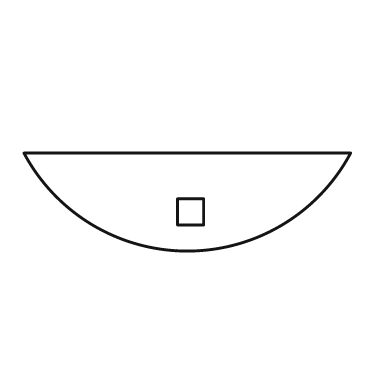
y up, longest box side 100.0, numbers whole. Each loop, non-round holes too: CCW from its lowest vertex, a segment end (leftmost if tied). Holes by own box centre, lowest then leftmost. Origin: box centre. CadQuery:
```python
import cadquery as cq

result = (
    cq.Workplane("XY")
    .moveTo(-50.0, 15.0)
    .threePointArc((0.0, -15.0), (50.0, 15.0))
    .close()
    .moveTo(-3.0, -7.0)
    .lineTo(5.0, -7.0)
    .lineTo(5.0, 1.0)
    .lineTo(-3.0, 1.0)
    .close()
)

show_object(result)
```